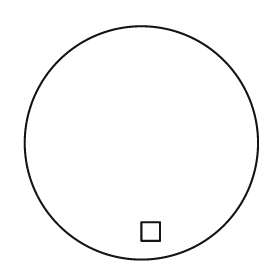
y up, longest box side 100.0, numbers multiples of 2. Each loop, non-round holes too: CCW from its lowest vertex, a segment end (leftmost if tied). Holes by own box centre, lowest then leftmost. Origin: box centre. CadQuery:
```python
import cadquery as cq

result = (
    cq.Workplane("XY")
    .moveTo(0.0, 0.0)
    .circle(50.0)
    .moveTo(0.0, -42.0)
    .lineTo(8.0, -42.0)
    .lineTo(8.0, -34.0)
    .lineTo(0.0, -34.0)
    .close()
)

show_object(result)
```